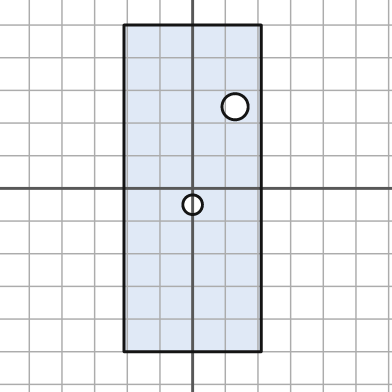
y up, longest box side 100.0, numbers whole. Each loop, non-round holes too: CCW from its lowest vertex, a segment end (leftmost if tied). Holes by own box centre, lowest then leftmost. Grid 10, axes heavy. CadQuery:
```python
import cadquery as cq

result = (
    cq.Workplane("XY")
    .moveTo(-21.0, -50.0)
    .lineTo(21.0, -50.0)
    .lineTo(21.0, 50.0)
    .lineTo(-21.0, 50.0)
    .close()
    .moveTo(0.0, -5.0)
    .circle(3.0)
    .moveTo(13.0, 25.0)
    .circle(4.0)
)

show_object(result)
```